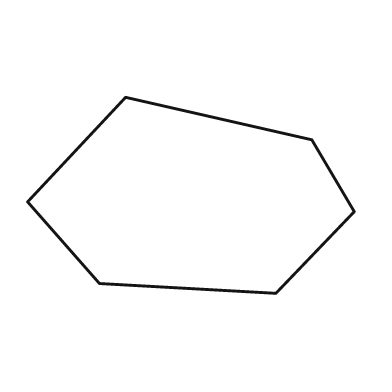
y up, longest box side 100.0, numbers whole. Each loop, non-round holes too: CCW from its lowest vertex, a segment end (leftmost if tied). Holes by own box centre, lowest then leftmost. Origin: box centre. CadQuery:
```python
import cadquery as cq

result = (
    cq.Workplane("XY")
    .moveTo(26.0, -30.0)
    .lineTo(50.0, -5.0)
    .lineTo(37.0, 17.0)
    .lineTo(-20.0, 30.0)
    .lineTo(-50.0, -2.0)
    .lineTo(-28.0, -27.0)
    .close()
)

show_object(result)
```